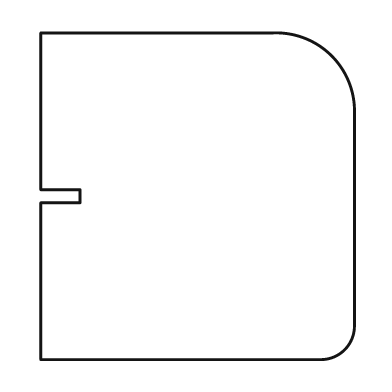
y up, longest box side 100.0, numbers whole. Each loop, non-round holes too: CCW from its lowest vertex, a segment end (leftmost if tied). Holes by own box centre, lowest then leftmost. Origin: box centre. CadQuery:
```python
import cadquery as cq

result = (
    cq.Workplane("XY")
    .moveTo(-48.0, -50.0)
    .lineTo(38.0, -50.0)
    .threePointArc((45.0, -47.0), (48.0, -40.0))
    .lineTo(48.0, 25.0)
    .threePointArc((41.0, 43.0), (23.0, 50.0))
    .lineTo(-48.0, 50.0)
    .lineTo(-48.0, 2.0)
    .lineTo(-36.0, 2.0)
    .lineTo(-36.0, -2.0)
    .lineTo(-48.0, -2.0)
    .close()
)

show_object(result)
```